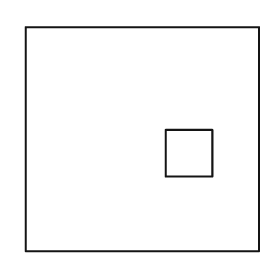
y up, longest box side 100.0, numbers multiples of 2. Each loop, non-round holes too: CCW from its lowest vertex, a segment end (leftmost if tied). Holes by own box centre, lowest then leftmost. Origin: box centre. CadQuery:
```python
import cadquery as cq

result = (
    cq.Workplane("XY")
    .moveTo(-50.0, -48.0)
    .lineTo(50.0, -48.0)
    .lineTo(50.0, 48.0)
    .lineTo(-50.0, 48.0)
    .close()
    .moveTo(10.0, -16.0)
    .lineTo(30.0, -16.0)
    .lineTo(30.0, 4.0)
    .lineTo(10.0, 4.0)
    .close()
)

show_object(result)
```